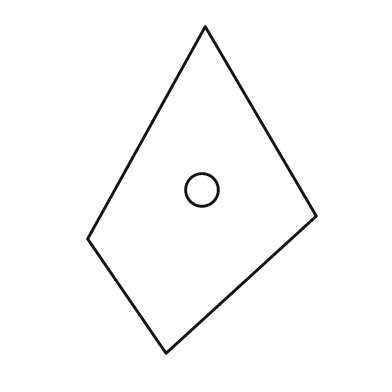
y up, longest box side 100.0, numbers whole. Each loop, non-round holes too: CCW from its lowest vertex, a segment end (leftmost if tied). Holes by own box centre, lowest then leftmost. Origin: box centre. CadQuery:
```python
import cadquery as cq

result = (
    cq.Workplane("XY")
    .moveTo(-11.0, -50.0)
    .lineTo(35.0, -8.0)
    .lineTo(1.0, 50.0)
    .lineTo(-35.0, -15.0)
    .close()
    .moveTo(0.0, 0.0)
    .circle(5.0)
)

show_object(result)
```